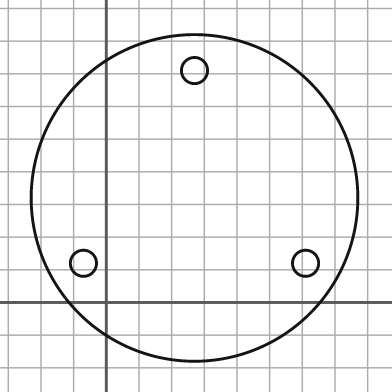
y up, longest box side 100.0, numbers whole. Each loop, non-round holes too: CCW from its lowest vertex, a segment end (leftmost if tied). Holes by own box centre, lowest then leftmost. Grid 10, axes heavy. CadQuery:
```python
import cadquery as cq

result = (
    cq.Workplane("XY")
    .moveTo(27.0, 32.0)
    .circle(50.0)
    .moveTo(-7.0, 12.0)
    .circle(4.0)
    .moveTo(61.0, 12.0)
    .circle(4.0)
    .moveTo(27.0, 71.0)
    .circle(4.0)
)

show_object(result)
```